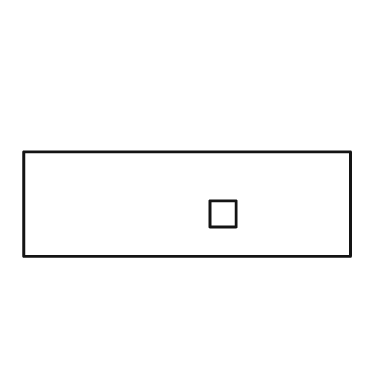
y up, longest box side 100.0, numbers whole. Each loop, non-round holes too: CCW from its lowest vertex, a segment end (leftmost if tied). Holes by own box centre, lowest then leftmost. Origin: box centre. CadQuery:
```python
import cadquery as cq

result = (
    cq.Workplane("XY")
    .moveTo(-50.0, -16.0)
    .lineTo(50.0, -16.0)
    .lineTo(50.0, 16.0)
    .lineTo(-50.0, 16.0)
    .close()
    .moveTo(7.0, -7.0)
    .lineTo(15.0, -7.0)
    .lineTo(15.0, 1.0)
    .lineTo(7.0, 1.0)
    .close()
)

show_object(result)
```